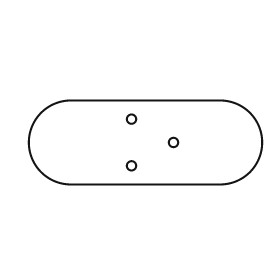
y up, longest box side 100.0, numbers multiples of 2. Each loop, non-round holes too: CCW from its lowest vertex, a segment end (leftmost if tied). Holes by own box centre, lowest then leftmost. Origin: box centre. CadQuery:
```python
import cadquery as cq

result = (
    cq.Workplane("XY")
    .moveTo(-32.0, -18.0)
    .lineTo(32.0, -18.0)
    .threePointArc((50.0, 0.0), (32.0, 18.0))
    .lineTo(-32.0, 18.0)
    .threePointArc((-50.0, 0.0), (-32.0, -18.0))
    .close()
    .moveTo(-6.0, -10.0)
    .circle(2.0)
    .moveTo(12.0, 0.0)
    .circle(2.0)
    .moveTo(-6.0, 10.0)
    .circle(2.0)
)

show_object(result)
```